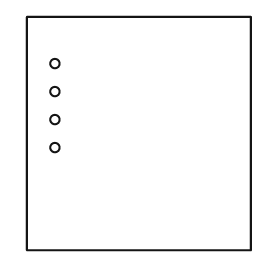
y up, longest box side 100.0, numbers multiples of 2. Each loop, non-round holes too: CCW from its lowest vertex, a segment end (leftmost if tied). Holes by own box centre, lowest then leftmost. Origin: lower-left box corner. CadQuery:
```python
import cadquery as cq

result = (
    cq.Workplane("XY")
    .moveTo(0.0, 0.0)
    .lineTo(96.0, 0.0)
    .lineTo(96.0, 100.0)
    .lineTo(0.0, 100.0)
    .close()
    .moveTo(12.0, 44.0)
    .circle(2.0)
    .moveTo(12.0, 56.0)
    .circle(2.0)
    .moveTo(12.0, 68.0)
    .circle(2.0)
    .moveTo(12.0, 80.0)
    .circle(2.0)
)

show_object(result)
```